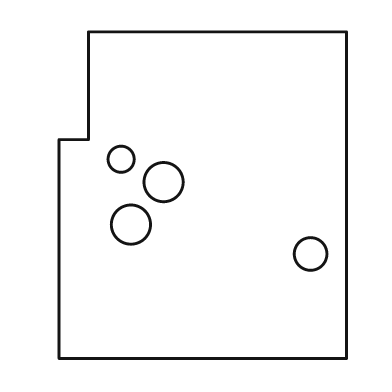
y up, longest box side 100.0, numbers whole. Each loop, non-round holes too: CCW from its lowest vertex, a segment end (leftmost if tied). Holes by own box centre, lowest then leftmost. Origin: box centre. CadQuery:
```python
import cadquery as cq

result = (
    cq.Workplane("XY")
    .moveTo(-44.0, -50.0)
    .lineTo(44.0, -50.0)
    .lineTo(44.0, 50.0)
    .lineTo(-35.0, 50.0)
    .lineTo(-35.0, 17.0)
    .lineTo(-44.0, 17.0)
    .close()
    .moveTo(33.0, -18.0)
    .circle(5.0)
    .moveTo(-22.0, -9.0)
    .circle(6.0)
    .moveTo(-12.0, 4.0)
    .circle(6.0)
    .moveTo(-25.0, 11.0)
    .circle(4.0)
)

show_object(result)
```